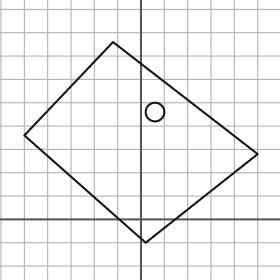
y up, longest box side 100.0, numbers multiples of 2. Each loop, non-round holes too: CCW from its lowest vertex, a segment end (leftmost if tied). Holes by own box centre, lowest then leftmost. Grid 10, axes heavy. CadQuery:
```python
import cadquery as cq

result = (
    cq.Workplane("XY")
    .moveTo(2.0, -10.0)
    .lineTo(50.0, 28.0)
    .lineTo(-12.0, 76.0)
    .lineTo(-50.0, 36.0)
    .close()
    .moveTo(6.0, 46.0)
    .circle(4.0)
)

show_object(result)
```